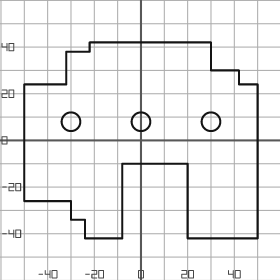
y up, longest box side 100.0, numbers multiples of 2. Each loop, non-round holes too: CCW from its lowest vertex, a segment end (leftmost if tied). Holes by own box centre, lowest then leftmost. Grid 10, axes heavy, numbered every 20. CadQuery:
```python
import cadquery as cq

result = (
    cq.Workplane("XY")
    .moveTo(-24.0, -42.0)
    .lineTo(-8.0, -42.0)
    .lineTo(-8.0, -10.0)
    .lineTo(20.0, -10.0)
    .lineTo(20.0, -42.0)
    .lineTo(50.0, -42.0)
    .lineTo(50.0, 24.0)
    .lineTo(42.0, 24.0)
    .lineTo(42.0, 30.0)
    .lineTo(30.0, 30.0)
    .lineTo(30.0, 42.0)
    .lineTo(-22.0, 42.0)
    .lineTo(-22.0, 38.0)
    .lineTo(-32.0, 38.0)
    .lineTo(-32.0, 24.0)
    .lineTo(-50.0, 24.0)
    .lineTo(-50.0, -26.0)
    .lineTo(-30.0, -26.0)
    .lineTo(-30.0, -34.0)
    .lineTo(-24.0, -34.0)
    .close()
    .moveTo(-30.0, 8.0)
    .circle(4.0)
    .moveTo(0.0, 8.0)
    .circle(4.0)
    .moveTo(30.0, 8.0)
    .circle(4.0)
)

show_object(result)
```